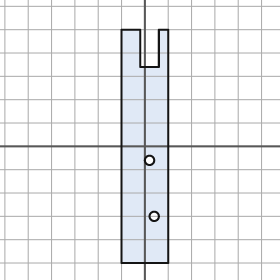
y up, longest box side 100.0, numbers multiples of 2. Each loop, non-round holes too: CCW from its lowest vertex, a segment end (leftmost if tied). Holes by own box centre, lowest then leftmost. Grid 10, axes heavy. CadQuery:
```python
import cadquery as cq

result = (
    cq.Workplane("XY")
    .moveTo(-10.0, -50.0)
    .lineTo(10.0, -50.0)
    .lineTo(10.0, 50.0)
    .lineTo(6.0, 50.0)
    .lineTo(6.0, 34.0)
    .lineTo(-2.0, 34.0)
    .lineTo(-2.0, 50.0)
    .lineTo(-10.0, 50.0)
    .close()
    .moveTo(4.0, -30.0)
    .circle(2.0)
    .moveTo(2.0, -6.0)
    .circle(2.0)
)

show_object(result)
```